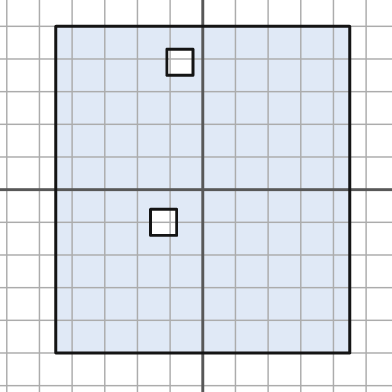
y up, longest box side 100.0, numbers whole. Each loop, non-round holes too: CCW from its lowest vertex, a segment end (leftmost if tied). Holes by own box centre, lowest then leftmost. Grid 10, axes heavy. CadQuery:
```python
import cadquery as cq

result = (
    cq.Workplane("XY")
    .moveTo(-45.0, -50.0)
    .lineTo(45.0, -50.0)
    .lineTo(45.0, 50.0)
    .lineTo(-45.0, 50.0)
    .close()
    .moveTo(-16.0, -14.0)
    .lineTo(-8.0, -14.0)
    .lineTo(-8.0, -6.0)
    .lineTo(-16.0, -6.0)
    .close()
    .moveTo(-11.0, 35.0)
    .lineTo(-3.0, 35.0)
    .lineTo(-3.0, 43.0)
    .lineTo(-11.0, 43.0)
    .close()
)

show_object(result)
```